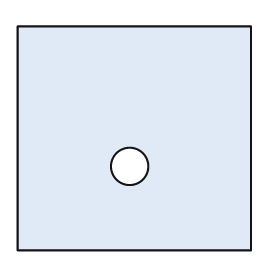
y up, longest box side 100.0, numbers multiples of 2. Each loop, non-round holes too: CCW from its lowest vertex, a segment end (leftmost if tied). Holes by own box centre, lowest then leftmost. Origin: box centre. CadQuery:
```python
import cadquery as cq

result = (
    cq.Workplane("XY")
    .moveTo(-50.0, -48.0)
    .lineTo(50.0, -48.0)
    .lineTo(50.0, 48.0)
    .lineTo(-50.0, 48.0)
    .close()
    .moveTo(-2.0, -12.0)
    .circle(8.0)
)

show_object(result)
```